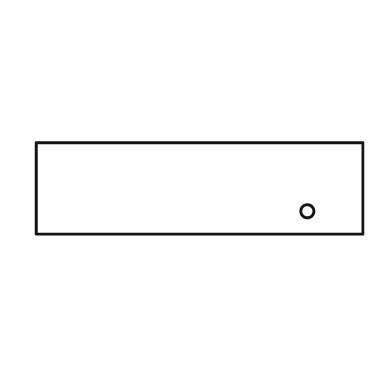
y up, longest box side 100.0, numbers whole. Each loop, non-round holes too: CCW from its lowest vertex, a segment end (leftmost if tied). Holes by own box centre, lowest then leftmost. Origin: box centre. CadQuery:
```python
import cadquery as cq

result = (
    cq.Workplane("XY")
    .moveTo(-50.0, -14.0)
    .lineTo(50.0, -14.0)
    .lineTo(50.0, 14.0)
    .lineTo(-50.0, 14.0)
    .close()
    .moveTo(33.0, -7.0)
    .circle(2.0)
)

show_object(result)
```